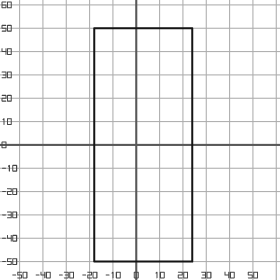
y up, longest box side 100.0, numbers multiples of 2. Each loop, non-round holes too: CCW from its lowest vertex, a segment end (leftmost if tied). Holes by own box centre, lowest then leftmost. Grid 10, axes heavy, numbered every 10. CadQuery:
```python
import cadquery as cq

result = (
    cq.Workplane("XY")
    .moveTo(-18.0, -50.0)
    .lineTo(24.0, -50.0)
    .lineTo(24.0, 50.0)
    .lineTo(-18.0, 50.0)
    .close()
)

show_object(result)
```